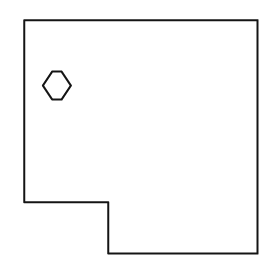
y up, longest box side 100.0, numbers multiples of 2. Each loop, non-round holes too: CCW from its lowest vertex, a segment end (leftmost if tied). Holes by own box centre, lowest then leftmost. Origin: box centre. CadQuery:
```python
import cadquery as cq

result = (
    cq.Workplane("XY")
    .moveTo(-14.0, -50.0)
    .lineTo(50.0, -50.0)
    .lineTo(50.0, 50.0)
    .lineTo(-50.0, 50.0)
    .lineTo(-50.0, -28.0)
    .lineTo(-14.0, -28.0)
    .close()
    .moveTo(-38.0, 16.0)
    .lineTo(-34.0, 16.0)
    .lineTo(-30.0, 22.0)
    .lineTo(-34.0, 28.0)
    .lineTo(-38.0, 28.0)
    .lineTo(-42.0, 22.0)
    .close()
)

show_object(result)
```